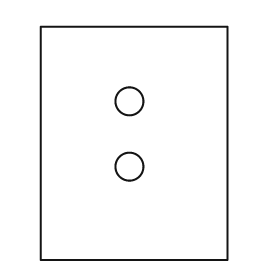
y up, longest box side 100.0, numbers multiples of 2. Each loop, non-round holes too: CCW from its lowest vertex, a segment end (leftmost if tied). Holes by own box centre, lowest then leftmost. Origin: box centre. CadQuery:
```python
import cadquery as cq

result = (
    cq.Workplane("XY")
    .moveTo(-40.0, -50.0)
    .lineTo(40.0, -50.0)
    .lineTo(40.0, 50.0)
    .lineTo(-40.0, 50.0)
    .close()
    .moveTo(-2.0, -10.0)
    .circle(6.0)
    .moveTo(-2.0, 18.0)
    .circle(6.0)
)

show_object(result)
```